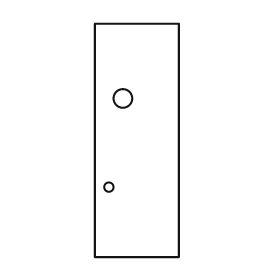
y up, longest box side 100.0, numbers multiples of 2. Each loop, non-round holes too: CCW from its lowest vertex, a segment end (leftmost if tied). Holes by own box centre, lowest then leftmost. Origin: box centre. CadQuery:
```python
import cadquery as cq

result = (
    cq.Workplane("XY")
    .moveTo(-18.0, -50.0)
    .lineTo(18.0, -50.0)
    .lineTo(18.0, 50.0)
    .lineTo(-18.0, 50.0)
    .close()
    .moveTo(-12.0, -20.0)
    .circle(2.0)
    .moveTo(-6.0, 18.0)
    .circle(4.0)
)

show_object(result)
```